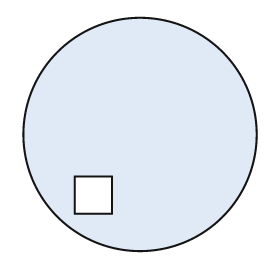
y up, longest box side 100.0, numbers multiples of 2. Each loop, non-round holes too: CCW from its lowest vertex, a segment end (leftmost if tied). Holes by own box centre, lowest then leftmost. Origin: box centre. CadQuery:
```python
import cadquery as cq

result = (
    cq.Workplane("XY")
    .moveTo(0.0, 0.0)
    .circle(50.0)
    .moveTo(-28.0, -34.0)
    .lineTo(-12.0, -34.0)
    .lineTo(-12.0, -18.0)
    .lineTo(-28.0, -18.0)
    .close()
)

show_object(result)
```